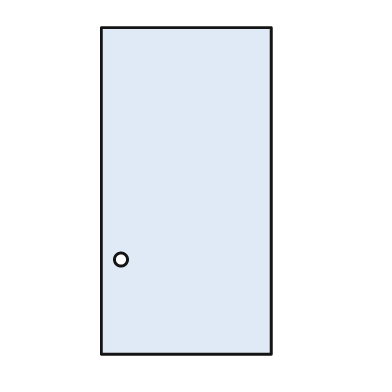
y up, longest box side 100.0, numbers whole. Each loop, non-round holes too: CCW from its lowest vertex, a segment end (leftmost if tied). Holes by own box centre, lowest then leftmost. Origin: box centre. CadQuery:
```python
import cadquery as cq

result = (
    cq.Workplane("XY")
    .moveTo(-26.0, -50.0)
    .lineTo(26.0, -50.0)
    .lineTo(26.0, 50.0)
    .lineTo(-26.0, 50.0)
    .close()
    .moveTo(-20.0, -21.0)
    .circle(2.0)
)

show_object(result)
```